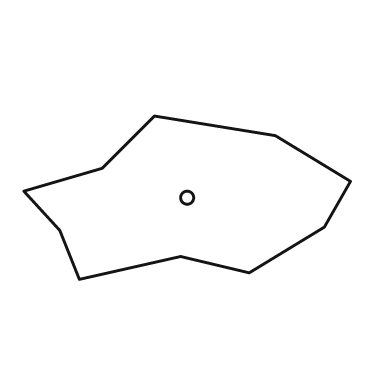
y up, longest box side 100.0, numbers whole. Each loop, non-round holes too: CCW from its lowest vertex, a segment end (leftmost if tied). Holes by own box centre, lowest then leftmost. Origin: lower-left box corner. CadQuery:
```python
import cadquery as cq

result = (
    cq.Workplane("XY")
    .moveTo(17.0, 0.0)
    .lineTo(48.0, 7.0)
    .lineTo(69.0, 2.0)
    .lineTo(92.0, 16.0)
    .lineTo(100.0, 30.0)
    .lineTo(77.0, 44.0)
    .lineTo(40.0, 50.0)
    .lineTo(24.0, 34.0)
    .lineTo(0.0, 27.0)
    .lineTo(11.0, 15.0)
    .close()
    .moveTo(50.0, 25.0)
    .circle(2.0)
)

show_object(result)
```